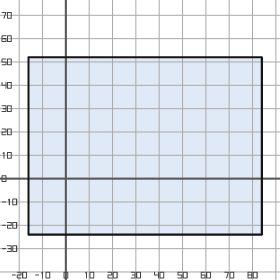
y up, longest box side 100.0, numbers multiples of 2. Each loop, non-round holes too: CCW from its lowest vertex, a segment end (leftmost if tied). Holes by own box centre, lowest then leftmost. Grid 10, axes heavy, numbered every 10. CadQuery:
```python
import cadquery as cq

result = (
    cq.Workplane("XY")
    .moveTo(-16.0, -24.0)
    .lineTo(84.0, -24.0)
    .lineTo(84.0, 52.0)
    .lineTo(-16.0, 52.0)
    .close()
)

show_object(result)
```